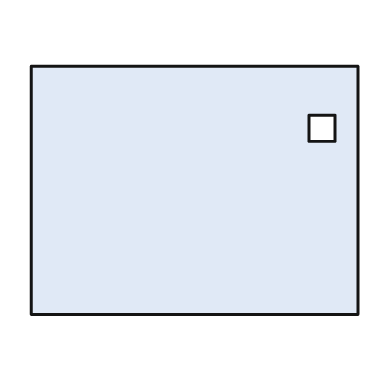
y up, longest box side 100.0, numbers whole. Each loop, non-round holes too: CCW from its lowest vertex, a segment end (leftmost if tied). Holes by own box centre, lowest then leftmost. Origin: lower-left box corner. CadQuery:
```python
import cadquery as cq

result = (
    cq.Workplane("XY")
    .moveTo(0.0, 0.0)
    .lineTo(100.0, 0.0)
    .lineTo(100.0, 76.0)
    .lineTo(0.0, 76.0)
    .close()
    .moveTo(85.0, 53.0)
    .lineTo(93.0, 53.0)
    .lineTo(93.0, 61.0)
    .lineTo(85.0, 61.0)
    .close()
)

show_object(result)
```